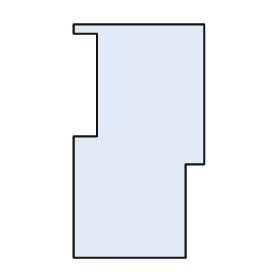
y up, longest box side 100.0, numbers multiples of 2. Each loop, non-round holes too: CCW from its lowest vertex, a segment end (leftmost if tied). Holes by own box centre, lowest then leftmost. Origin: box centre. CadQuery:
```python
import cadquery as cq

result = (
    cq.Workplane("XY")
    .moveTo(-28.0, -50.0)
    .lineTo(20.0, -50.0)
    .lineTo(20.0, -10.0)
    .lineTo(28.0, -10.0)
    .lineTo(28.0, 50.0)
    .lineTo(-28.0, 50.0)
    .lineTo(-28.0, 46.0)
    .lineTo(-18.0, 46.0)
    .lineTo(-18.0, 2.0)
    .lineTo(-28.0, 2.0)
    .close()
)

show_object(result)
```